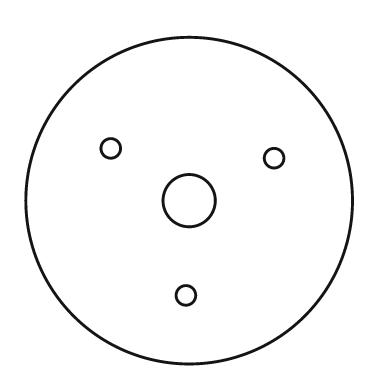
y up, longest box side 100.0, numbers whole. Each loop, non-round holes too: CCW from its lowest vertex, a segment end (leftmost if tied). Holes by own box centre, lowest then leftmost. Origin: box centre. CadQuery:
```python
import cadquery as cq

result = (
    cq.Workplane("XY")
    .moveTo(0.0, 0.0)
    .circle(50.0)
    .moveTo(-1.0, -29.0)
    .circle(3.0)
    .moveTo(0.0, 0.0)
    .circle(8.0)
    .moveTo(26.0, 13.0)
    .circle(3.0)
    .moveTo(-24.0, 16.0)
    .circle(3.0)
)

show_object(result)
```